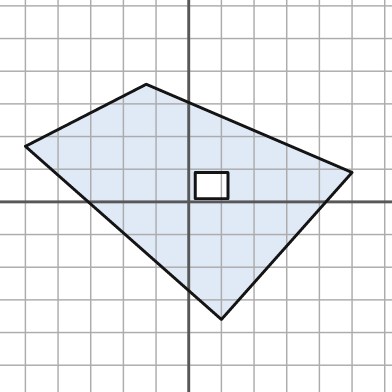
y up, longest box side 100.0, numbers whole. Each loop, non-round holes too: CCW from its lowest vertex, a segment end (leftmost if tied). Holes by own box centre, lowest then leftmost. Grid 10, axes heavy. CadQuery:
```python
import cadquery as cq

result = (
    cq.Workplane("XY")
    .moveTo(10.0, -36.0)
    .lineTo(50.0, 9.0)
    .lineTo(-13.0, 36.0)
    .lineTo(-50.0, 17.0)
    .close()
    .moveTo(2.0, 1.0)
    .lineTo(12.0, 1.0)
    .lineTo(12.0, 9.0)
    .lineTo(2.0, 9.0)
    .close()
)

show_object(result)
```